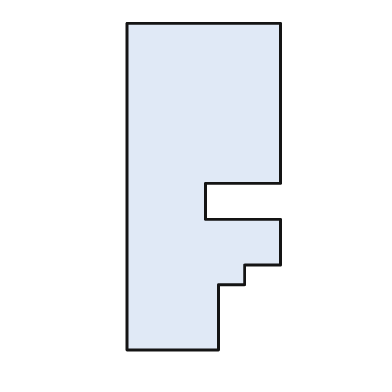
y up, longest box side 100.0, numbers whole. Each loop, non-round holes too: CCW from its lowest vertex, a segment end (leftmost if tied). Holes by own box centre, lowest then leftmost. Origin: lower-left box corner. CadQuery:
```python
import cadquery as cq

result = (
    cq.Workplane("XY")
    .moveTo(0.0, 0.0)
    .lineTo(28.0, 0.0)
    .lineTo(28.0, 20.0)
    .lineTo(36.0, 20.0)
    .lineTo(36.0, 26.0)
    .lineTo(47.0, 26.0)
    .lineTo(47.0, 40.0)
    .lineTo(24.0, 40.0)
    .lineTo(24.0, 51.0)
    .lineTo(47.0, 51.0)
    .lineTo(47.0, 100.0)
    .lineTo(0.0, 100.0)
    .close()
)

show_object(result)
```